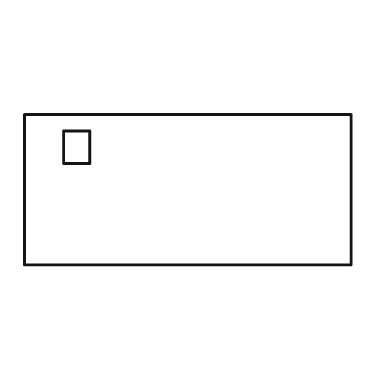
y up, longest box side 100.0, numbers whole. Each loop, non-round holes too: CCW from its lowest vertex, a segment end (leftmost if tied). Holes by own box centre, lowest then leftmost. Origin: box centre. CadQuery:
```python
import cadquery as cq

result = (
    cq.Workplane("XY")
    .moveTo(-50.0, -23.0)
    .lineTo(50.0, -23.0)
    .lineTo(50.0, 23.0)
    .lineTo(-50.0, 23.0)
    .close()
    .moveTo(-38.0, 8.0)
    .lineTo(-30.0, 8.0)
    .lineTo(-30.0, 18.0)
    .lineTo(-38.0, 18.0)
    .close()
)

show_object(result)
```